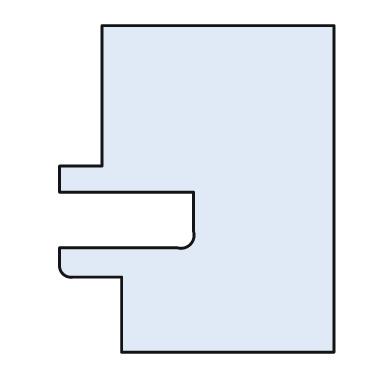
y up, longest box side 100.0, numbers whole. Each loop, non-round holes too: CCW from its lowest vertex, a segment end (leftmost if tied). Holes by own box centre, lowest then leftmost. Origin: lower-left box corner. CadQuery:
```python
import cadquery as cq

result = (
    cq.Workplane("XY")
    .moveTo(19.0, 0.0)
    .lineTo(84.0, 0.0)
    .lineTo(84.0, 100.0)
    .lineTo(13.0, 100.0)
    .lineTo(13.0, 57.0)
    .lineTo(0.0, 57.0)
    .lineTo(0.0, 49.0)
    .lineTo(41.0, 49.0)
    .lineTo(41.0, 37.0)
    .threePointArc((40.0, 33.0), (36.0, 32.0))
    .lineTo(0.0, 32.0)
    .lineTo(0.0, 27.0)
    .threePointArc((1.0, 24.0), (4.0, 23.0))
    .lineTo(19.0, 23.0)
    .close()
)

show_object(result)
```